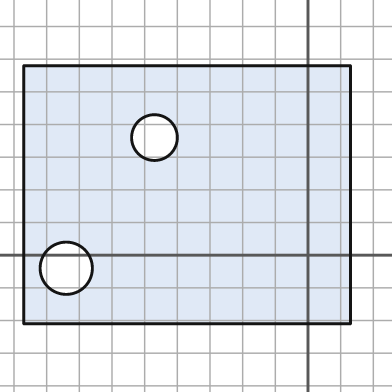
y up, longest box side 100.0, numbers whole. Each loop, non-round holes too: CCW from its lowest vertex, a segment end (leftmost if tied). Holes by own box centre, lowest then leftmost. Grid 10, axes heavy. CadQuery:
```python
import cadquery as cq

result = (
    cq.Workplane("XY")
    .moveTo(-87.0, -21.0)
    .lineTo(13.0, -21.0)
    .lineTo(13.0, 58.0)
    .lineTo(-87.0, 58.0)
    .close()
    .moveTo(-74.0, -4.0)
    .circle(8.0)
    .moveTo(-47.0, 36.0)
    .circle(7.0)
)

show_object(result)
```